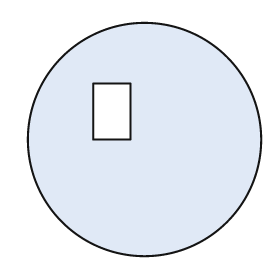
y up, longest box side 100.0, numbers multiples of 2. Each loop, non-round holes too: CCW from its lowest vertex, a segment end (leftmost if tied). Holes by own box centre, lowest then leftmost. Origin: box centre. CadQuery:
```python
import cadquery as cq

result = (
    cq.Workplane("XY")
    .moveTo(0.0, 0.0)
    .circle(50.0)
    .moveTo(-22.0, 0.0)
    .lineTo(-6.0, 0.0)
    .lineTo(-6.0, 24.0)
    .lineTo(-22.0, 24.0)
    .close()
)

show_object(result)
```